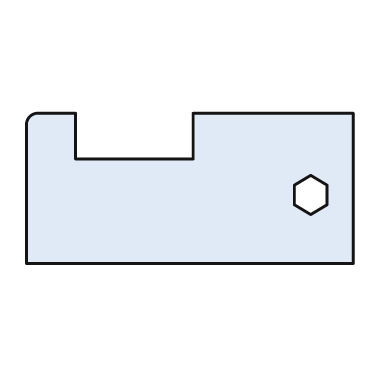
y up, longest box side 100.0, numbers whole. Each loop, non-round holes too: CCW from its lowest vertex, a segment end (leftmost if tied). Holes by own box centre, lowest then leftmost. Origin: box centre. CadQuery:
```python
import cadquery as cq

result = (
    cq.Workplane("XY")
    .moveTo(-50.0, -23.0)
    .lineTo(50.0, -23.0)
    .lineTo(50.0, 23.0)
    .lineTo(1.0, 23.0)
    .lineTo(1.0, 9.0)
    .lineTo(-35.0, 9.0)
    .lineTo(-35.0, 23.0)
    .lineTo(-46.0, 23.0)
    .threePointArc((-49.0, 22.0), (-50.0, 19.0))
    .close()
    .moveTo(37.0, -8.0)
    .lineTo(42.0, -5.0)
    .lineTo(42.0, 1.0)
    .lineTo(37.0, 4.0)
    .lineTo(32.0, 1.0)
    .lineTo(32.0, -5.0)
    .close()
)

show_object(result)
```